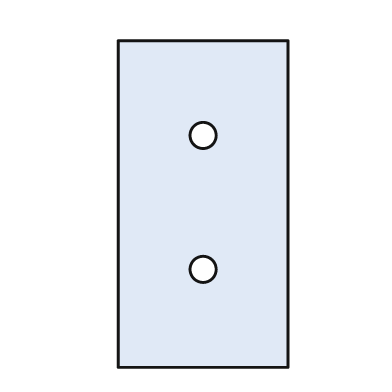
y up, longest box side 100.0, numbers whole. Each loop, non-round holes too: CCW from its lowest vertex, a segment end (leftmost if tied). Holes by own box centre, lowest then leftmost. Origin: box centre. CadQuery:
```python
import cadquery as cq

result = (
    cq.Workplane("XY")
    .moveTo(-26.0, -50.0)
    .lineTo(26.0, -50.0)
    .lineTo(26.0, 50.0)
    .lineTo(-26.0, 50.0)
    .close()
    .moveTo(0.0, -20.0)
    .circle(4.0)
    .moveTo(0.0, 21.0)
    .circle(4.0)
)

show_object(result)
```